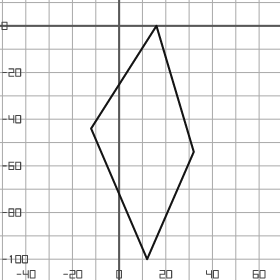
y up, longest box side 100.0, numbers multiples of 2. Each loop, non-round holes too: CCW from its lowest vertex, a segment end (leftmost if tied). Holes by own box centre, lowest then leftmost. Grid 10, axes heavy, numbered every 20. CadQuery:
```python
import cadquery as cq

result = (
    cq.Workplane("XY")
    .moveTo(12.0, -100.0)
    .lineTo(32.0, -54.0)
    .lineTo(16.0, 0.0)
    .lineTo(-12.0, -44.0)
    .close()
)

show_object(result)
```